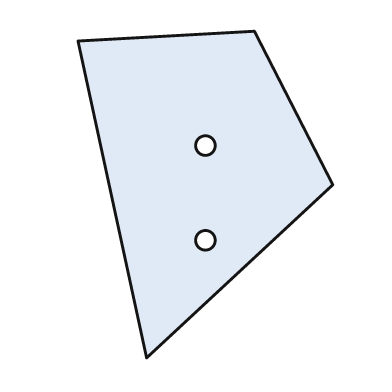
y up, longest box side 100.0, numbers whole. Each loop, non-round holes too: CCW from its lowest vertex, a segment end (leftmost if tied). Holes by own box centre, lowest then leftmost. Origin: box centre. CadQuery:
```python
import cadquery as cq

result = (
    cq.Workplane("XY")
    .moveTo(-18.0, -50.0)
    .lineTo(39.0, 3.0)
    .lineTo(15.0, 50.0)
    .lineTo(-39.0, 47.0)
    .close()
    .moveTo(0.0, -14.0)
    .circle(3.0)
    .moveTo(0.0, 15.0)
    .circle(3.0)
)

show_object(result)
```